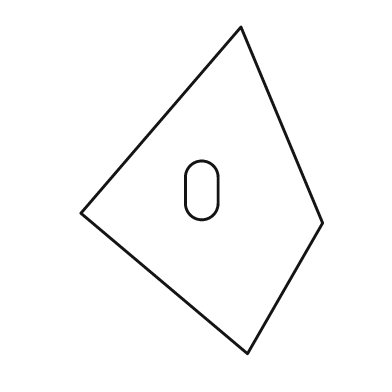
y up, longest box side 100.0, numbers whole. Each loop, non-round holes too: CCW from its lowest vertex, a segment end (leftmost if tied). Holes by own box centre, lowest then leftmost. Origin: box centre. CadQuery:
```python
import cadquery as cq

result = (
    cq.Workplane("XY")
    .moveTo(14.0, -50.0)
    .lineTo(37.0, -10.0)
    .lineTo(12.0, 50.0)
    .lineTo(-37.0, -7.0)
    .close()
    .moveTo(-5.0, -4.0)
    .threePointArc((0.0, -9.0), (5.0, -4.0))
    .lineTo(5.0, 4.0)
    .threePointArc((0.0, 9.0), (-5.0, 4.0))
    .close()
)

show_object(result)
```